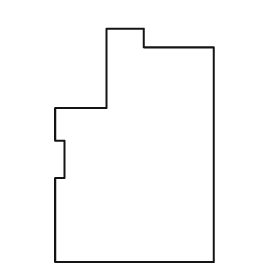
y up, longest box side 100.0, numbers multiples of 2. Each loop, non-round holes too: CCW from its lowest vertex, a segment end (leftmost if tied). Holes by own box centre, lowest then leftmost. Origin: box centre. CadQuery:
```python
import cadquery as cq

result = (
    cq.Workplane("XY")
    .moveTo(-34.0, -50.0)
    .lineTo(34.0, -50.0)
    .lineTo(34.0, 42.0)
    .lineTo(4.0, 42.0)
    .lineTo(4.0, 50.0)
    .lineTo(-12.0, 50.0)
    .lineTo(-12.0, 16.0)
    .lineTo(-34.0, 16.0)
    .lineTo(-34.0, 2.0)
    .lineTo(-30.0, 2.0)
    .lineTo(-30.0, -14.0)
    .lineTo(-34.0, -14.0)
    .close()
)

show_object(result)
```